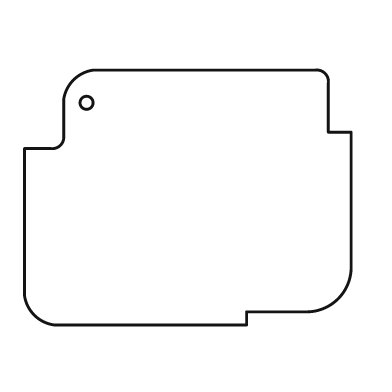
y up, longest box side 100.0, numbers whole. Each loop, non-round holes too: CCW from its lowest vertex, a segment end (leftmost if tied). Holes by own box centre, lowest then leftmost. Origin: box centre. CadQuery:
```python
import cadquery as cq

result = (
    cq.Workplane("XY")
    .moveTo(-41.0, -39.0)
    .lineTo(18.0, -39.0)
    .lineTo(18.0, -35.0)
    .lineTo(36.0, -35.0)
    .threePointArc((46.0, -31.0), (50.0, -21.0))
    .lineTo(50.0, 20.0)
    .lineTo(43.0, 20.0)
    .lineTo(43.0, 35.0)
    .threePointArc((42.0, 38.0), (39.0, 39.0))
    .lineTo(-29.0, 39.0)
    .threePointArc((-35.0, 36.0), (-38.0, 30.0))
    .lineTo(-38.0, 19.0)
    .threePointArc((-39.0, 16.0), (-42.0, 15.0))
    .lineTo(-50.0, 15.0)
    .lineTo(-50.0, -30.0)
    .threePointArc((-47.0, -36.0), (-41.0, -39.0))
    .close()
    .moveTo(-31.0, 29.0)
    .circle(2.0)
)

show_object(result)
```